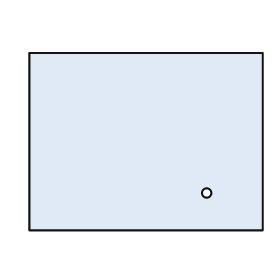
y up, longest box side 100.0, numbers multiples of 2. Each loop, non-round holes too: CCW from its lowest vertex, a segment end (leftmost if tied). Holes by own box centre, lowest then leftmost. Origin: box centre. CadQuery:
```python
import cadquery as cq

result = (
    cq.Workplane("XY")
    .moveTo(-50.0, -38.0)
    .lineTo(50.0, -38.0)
    .lineTo(50.0, 38.0)
    .lineTo(-50.0, 38.0)
    .close()
    .moveTo(26.0, -22.0)
    .circle(2.0)
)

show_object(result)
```